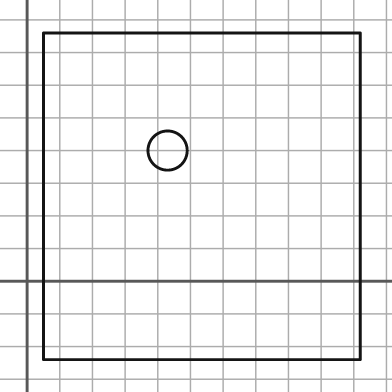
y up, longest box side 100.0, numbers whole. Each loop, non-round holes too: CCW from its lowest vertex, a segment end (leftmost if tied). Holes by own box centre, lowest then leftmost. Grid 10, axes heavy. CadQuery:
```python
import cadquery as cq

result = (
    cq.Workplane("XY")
    .moveTo(5.0, -24.0)
    .lineTo(102.0, -24.0)
    .lineTo(102.0, 76.0)
    .lineTo(5.0, 76.0)
    .close()
    .moveTo(43.0, 40.0)
    .circle(6.0)
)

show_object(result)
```